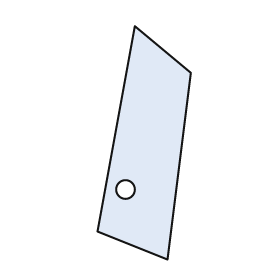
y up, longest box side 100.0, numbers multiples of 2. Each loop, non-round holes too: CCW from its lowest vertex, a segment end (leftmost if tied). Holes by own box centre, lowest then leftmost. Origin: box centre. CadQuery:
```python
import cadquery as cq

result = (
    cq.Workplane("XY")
    .moveTo(10.0, -50.0)
    .lineTo(20.0, 30.0)
    .lineTo(-4.0, 50.0)
    .lineTo(-20.0, -38.0)
    .close()
    .moveTo(-8.0, -20.0)
    .circle(4.0)
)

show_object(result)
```